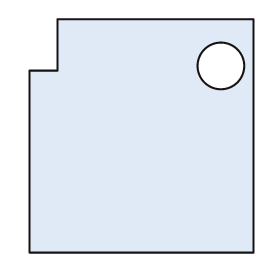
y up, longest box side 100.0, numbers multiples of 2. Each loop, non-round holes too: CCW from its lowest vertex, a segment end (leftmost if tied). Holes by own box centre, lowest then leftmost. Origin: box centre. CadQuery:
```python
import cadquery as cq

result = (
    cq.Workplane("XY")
    .moveTo(-48.0, -50.0)
    .lineTo(48.0, -50.0)
    .lineTo(48.0, 50.0)
    .lineTo(-36.0, 50.0)
    .lineTo(-36.0, 28.0)
    .lineTo(-48.0, 28.0)
    .close()
    .moveTo(34.0, 30.0)
    .circle(10.0)
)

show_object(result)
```